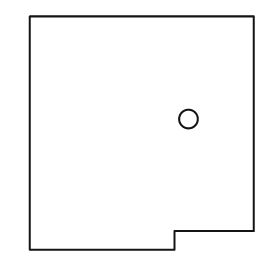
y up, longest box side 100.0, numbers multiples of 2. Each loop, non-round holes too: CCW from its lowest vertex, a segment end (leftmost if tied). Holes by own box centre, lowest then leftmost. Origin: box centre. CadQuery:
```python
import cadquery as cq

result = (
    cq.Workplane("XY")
    .moveTo(-48.0, -50.0)
    .lineTo(14.0, -50.0)
    .lineTo(14.0, -42.0)
    .lineTo(48.0, -42.0)
    .lineTo(48.0, 50.0)
    .lineTo(-48.0, 50.0)
    .close()
    .moveTo(20.0, 6.0)
    .circle(4.0)
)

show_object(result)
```